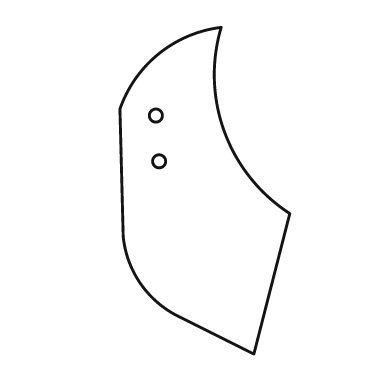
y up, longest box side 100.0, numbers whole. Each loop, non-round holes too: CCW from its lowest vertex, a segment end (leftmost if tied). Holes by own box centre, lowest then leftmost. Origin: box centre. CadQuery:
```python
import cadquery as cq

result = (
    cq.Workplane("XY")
    .moveTo(15.0, -50.0)
    .lineTo(26.0, -7.0)
    .threePointArc((6.0, 18.0), (5.0, 50.0))
    .threePointArc((-14.0, 42.0), (-26.0, 25.0))
    .lineTo(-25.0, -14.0)
    .threePointArc((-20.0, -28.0), (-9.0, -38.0))
    .close()
    .moveTo(-14.0, 9.0)
    .circle(2.0)
    .moveTo(-15.0, 23.0)
    .circle(2.0)
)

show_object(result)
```